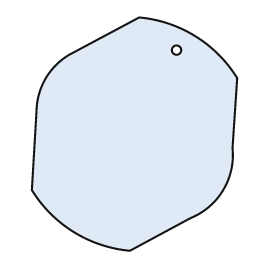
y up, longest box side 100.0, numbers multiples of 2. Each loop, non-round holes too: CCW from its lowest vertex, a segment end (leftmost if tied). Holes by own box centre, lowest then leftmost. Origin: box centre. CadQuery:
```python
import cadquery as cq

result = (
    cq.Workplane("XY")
    .moveTo(-2.0, -50.0)
    .lineTo(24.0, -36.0)
    .threePointArc((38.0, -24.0), (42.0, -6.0))
    .lineTo(44.0, 24.0)
    .threePointArc((26.0, 42.0), (2.0, 50.0))
    .lineTo(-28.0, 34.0)
    .threePointArc((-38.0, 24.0), (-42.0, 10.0))
    .lineTo(-44.0, -24.0)
    .threePointArc((-26.0, -42.0), (-2.0, -50.0))
    .close()
    .moveTo(18.0, 36.0)
    .circle(2.0)
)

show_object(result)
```